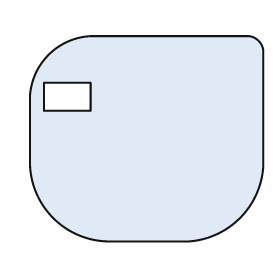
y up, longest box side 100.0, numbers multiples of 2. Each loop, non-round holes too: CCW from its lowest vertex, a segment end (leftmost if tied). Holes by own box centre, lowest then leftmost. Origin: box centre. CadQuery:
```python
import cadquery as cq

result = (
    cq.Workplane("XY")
    .moveTo(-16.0, -44.0)
    .lineTo(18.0, -44.0)
    .threePointArc((40.0, -34.0), (50.0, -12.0))
    .lineTo(50.0, 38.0)
    .threePointArc((48.0, 42.0), (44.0, 44.0))
    .lineTo(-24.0, 44.0)
    .threePointArc((-42.0, 36.0), (-50.0, 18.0))
    .lineTo(-50.0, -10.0)
    .threePointArc((-40.0, -34.0), (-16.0, -44.0))
    .close()
    .moveTo(-44.0, 12.0)
    .lineTo(-24.0, 12.0)
    .lineTo(-24.0, 24.0)
    .lineTo(-44.0, 24.0)
    .close()
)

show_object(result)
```